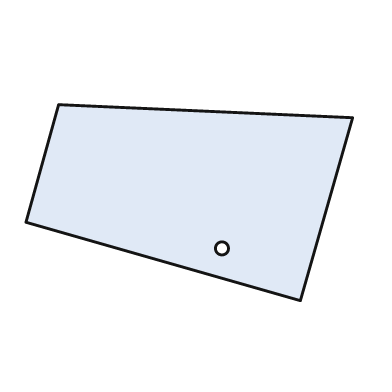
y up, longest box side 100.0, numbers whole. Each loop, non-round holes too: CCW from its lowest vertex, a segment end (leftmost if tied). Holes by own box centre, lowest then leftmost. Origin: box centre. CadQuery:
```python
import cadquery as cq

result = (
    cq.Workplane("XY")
    .moveTo(34.0, -30.0)
    .lineTo(50.0, 26.0)
    .lineTo(-40.0, 30.0)
    .lineTo(-50.0, -6.0)
    .close()
    .moveTo(10.0, -14.0)
    .circle(2.0)
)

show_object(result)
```